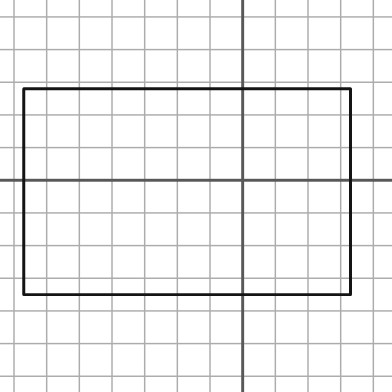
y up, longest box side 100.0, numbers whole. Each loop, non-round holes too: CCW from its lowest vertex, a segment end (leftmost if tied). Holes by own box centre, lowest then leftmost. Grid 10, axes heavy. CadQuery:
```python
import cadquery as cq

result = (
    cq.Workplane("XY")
    .moveTo(-67.0, -35.0)
    .lineTo(33.0, -35.0)
    .lineTo(33.0, 28.0)
    .lineTo(-67.0, 28.0)
    .close()
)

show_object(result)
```